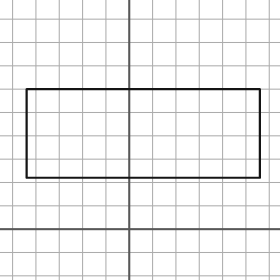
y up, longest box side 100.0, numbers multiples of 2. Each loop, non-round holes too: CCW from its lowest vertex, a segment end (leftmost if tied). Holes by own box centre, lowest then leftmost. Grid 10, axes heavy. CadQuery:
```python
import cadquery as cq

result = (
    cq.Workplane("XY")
    .moveTo(-44.0, 22.0)
    .lineTo(56.0, 22.0)
    .lineTo(56.0, 60.0)
    .lineTo(-44.0, 60.0)
    .close()
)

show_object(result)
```